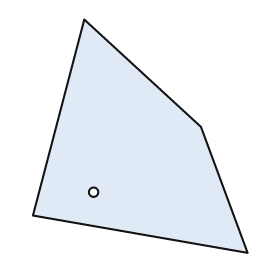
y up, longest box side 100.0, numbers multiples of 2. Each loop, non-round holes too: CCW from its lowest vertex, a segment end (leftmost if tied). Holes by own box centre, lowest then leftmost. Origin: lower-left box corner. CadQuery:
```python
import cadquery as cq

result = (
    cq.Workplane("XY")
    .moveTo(92.0, 0.0)
    .lineTo(72.0, 54.0)
    .lineTo(22.0, 100.0)
    .lineTo(0.0, 16.0)
    .close()
    .moveTo(26.0, 26.0)
    .circle(2.0)
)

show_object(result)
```